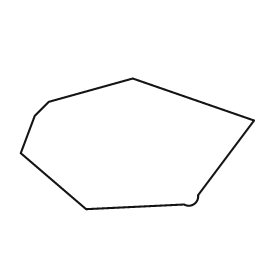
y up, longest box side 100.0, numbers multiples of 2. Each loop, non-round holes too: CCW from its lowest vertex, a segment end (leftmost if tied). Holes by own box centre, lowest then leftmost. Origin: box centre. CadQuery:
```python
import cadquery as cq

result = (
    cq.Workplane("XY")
    .moveTo(-22.0, -28.0)
    .lineTo(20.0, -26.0)
    .threePointArc((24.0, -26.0), (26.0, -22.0))
    .lineTo(50.0, 10.0)
    .lineTo(-2.0, 28.0)
    .lineTo(-38.0, 18.0)
    .lineTo(-44.0, 12.0)
    .lineTo(-50.0, -4.0)
    .close()
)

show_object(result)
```